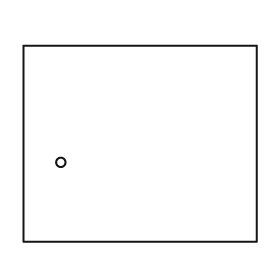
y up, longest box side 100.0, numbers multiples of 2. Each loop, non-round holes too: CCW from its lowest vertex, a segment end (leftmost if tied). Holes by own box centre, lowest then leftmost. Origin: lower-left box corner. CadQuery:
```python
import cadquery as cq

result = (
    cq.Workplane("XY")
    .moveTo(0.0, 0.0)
    .lineTo(100.0, 0.0)
    .lineTo(100.0, 84.0)
    .lineTo(0.0, 84.0)
    .close()
    .moveTo(16.0, 34.0)
    .circle(2.0)
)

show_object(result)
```